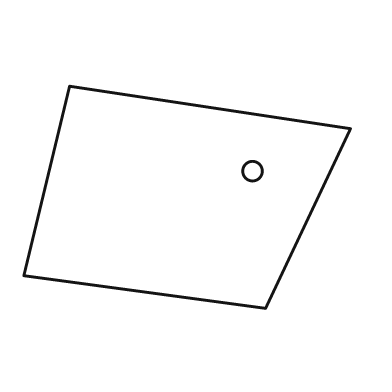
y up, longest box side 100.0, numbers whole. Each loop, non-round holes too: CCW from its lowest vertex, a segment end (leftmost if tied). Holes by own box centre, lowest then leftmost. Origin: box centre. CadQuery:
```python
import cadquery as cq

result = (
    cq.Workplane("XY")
    .moveTo(24.0, -34.0)
    .lineTo(50.0, 21.0)
    .lineTo(-36.0, 34.0)
    .lineTo(-50.0, -24.0)
    .close()
    .moveTo(20.0, 8.0)
    .circle(3.0)
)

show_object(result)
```